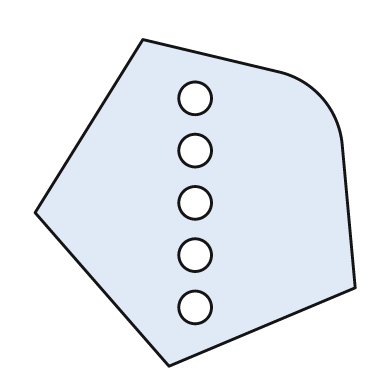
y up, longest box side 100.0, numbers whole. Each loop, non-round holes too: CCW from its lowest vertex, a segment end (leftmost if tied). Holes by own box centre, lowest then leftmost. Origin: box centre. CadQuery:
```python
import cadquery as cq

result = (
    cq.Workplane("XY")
    .moveTo(-8.0, -50.0)
    .lineTo(49.0, -26.0)
    .lineTo(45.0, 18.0)
    .threePointArc((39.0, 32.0), (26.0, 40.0))
    .lineTo(-16.0, 50.0)
    .lineTo(-49.0, -3.0)
    .close()
    .moveTo(0.0, -32.0)
    .circle(5.0)
    .moveTo(0.0, -16.0)
    .circle(5.0)
    .moveTo(0.0, 0.0)
    .circle(5.0)
    .moveTo(0.0, 16.0)
    .circle(5.0)
    .moveTo(0.0, 32.0)
    .circle(5.0)
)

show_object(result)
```